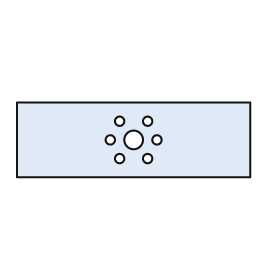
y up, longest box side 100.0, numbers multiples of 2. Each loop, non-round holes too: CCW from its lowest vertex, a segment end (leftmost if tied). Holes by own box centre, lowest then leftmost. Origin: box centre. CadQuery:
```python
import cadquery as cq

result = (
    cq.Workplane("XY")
    .moveTo(-50.0, -16.0)
    .lineTo(50.0, -16.0)
    .lineTo(50.0, 16.0)
    .lineTo(-50.0, 16.0)
    .close()
    .moveTo(-6.0, -8.0)
    .circle(2.0)
    .moveTo(6.0, -8.0)
    .circle(2.0)
    .moveTo(-10.0, 0.0)
    .circle(2.0)
    .moveTo(0.0, 0.0)
    .circle(4.0)
    .moveTo(10.0, 0.0)
    .circle(2.0)
    .moveTo(-6.0, 8.0)
    .circle(2.0)
    .moveTo(6.0, 8.0)
    .circle(2.0)
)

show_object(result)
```